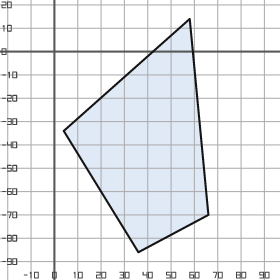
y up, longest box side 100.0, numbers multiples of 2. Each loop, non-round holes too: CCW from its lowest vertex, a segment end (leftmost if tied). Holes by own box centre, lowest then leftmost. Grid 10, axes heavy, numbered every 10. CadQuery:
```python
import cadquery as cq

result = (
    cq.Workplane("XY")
    .moveTo(36.0, -86.0)
    .lineTo(66.0, -70.0)
    .lineTo(58.0, 14.0)
    .lineTo(4.0, -34.0)
    .close()
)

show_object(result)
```